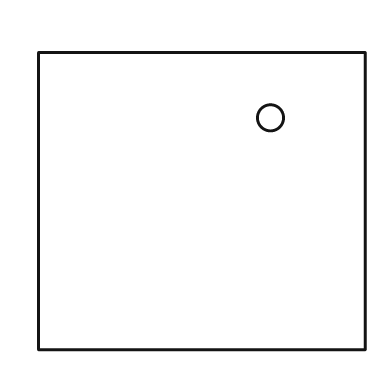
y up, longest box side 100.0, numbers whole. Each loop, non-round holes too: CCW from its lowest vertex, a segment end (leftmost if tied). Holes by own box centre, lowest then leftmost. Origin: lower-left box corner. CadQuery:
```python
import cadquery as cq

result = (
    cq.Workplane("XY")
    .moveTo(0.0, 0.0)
    .lineTo(100.0, 0.0)
    .lineTo(100.0, 91.0)
    .lineTo(0.0, 91.0)
    .close()
    .moveTo(71.0, 71.0)
    .circle(4.0)
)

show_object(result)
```